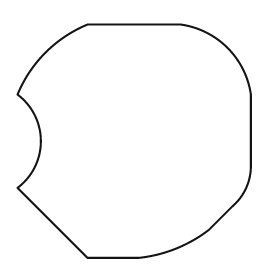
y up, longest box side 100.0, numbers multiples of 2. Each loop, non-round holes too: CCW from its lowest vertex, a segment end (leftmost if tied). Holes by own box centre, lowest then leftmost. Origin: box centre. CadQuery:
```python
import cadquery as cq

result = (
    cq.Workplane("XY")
    .moveTo(-20.0, -50.0)
    .lineTo(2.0, -50.0)
    .threePointArc((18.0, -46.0), (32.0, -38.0))
    .lineTo(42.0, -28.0)
    .threePointArc((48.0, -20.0), (50.0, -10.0))
    .lineTo(50.0, 20.0)
    .threePointArc((40.0, 40.0), (20.0, 50.0))
    .lineTo(-20.0, 50.0)
    .threePointArc((-38.0, 38.0), (-50.0, 20.0))
    .threePointArc((-40.0, 0.0), (-50.0, -20.0))
    .close()
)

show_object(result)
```